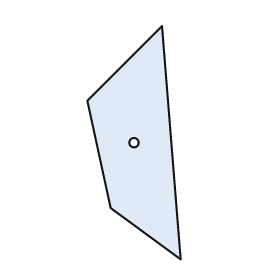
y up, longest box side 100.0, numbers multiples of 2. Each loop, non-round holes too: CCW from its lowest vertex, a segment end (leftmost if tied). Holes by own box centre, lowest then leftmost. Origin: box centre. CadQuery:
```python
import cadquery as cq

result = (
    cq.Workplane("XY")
    .moveTo(20.0, -50.0)
    .lineTo(12.0, 50.0)
    .lineTo(-20.0, 18.0)
    .lineTo(-10.0, -28.0)
    .close()
    .moveTo(0.0, 0.0)
    .circle(2.0)
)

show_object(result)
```